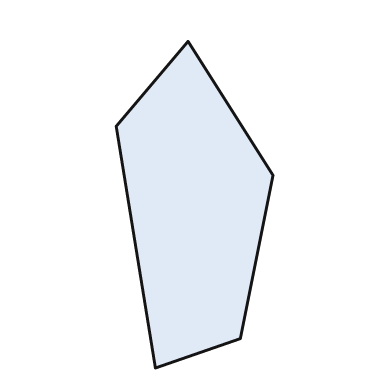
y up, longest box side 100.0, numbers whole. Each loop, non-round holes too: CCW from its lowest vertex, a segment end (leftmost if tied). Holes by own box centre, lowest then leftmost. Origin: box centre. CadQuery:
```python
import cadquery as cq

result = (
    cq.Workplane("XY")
    .moveTo(-12.0, -50.0)
    .lineTo(14.0, -41.0)
    .lineTo(24.0, 9.0)
    .lineTo(-2.0, 50.0)
    .lineTo(-24.0, 24.0)
    .close()
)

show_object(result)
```